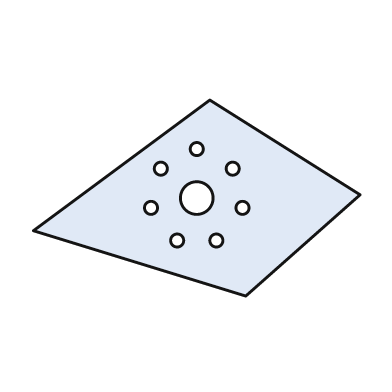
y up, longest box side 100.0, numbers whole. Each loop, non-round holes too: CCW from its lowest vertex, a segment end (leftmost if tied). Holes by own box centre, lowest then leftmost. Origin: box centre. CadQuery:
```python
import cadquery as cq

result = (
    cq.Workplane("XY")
    .moveTo(15.0, -30.0)
    .lineTo(50.0, 1.0)
    .lineTo(4.0, 30.0)
    .lineTo(-50.0, -10.0)
    .close()
    .moveTo(-6.0, -13.0)
    .circle(2.0)
    .moveTo(6.0, -13.0)
    .circle(2.0)
    .moveTo(-14.0, -3.0)
    .circle(2.0)
    .moveTo(14.0, -3.0)
    .circle(2.0)
    .moveTo(0.0, 0.0)
    .circle(5.0)
    .moveTo(-11.0, 9.0)
    .circle(2.0)
    .moveTo(11.0, 9.0)
    .circle(2.0)
    .moveTo(0.0, 15.0)
    .circle(2.0)
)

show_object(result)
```